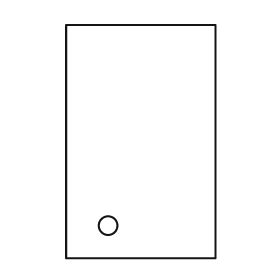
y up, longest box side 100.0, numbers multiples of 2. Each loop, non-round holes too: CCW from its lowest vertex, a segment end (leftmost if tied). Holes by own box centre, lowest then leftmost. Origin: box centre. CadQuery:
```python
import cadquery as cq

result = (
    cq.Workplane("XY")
    .moveTo(-32.0, -50.0)
    .lineTo(32.0, -50.0)
    .lineTo(32.0, 50.0)
    .lineTo(-32.0, 50.0)
    .close()
    .moveTo(-14.0, -36.0)
    .circle(4.0)
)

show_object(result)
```